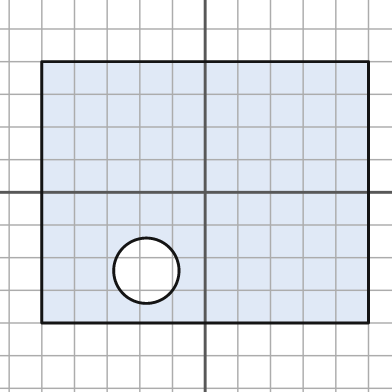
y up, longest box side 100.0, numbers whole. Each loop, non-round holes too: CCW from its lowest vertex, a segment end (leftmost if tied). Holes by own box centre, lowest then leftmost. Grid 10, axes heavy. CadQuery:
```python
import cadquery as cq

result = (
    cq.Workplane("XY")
    .moveTo(-50.0, -40.0)
    .lineTo(50.0, -40.0)
    .lineTo(50.0, 40.0)
    .lineTo(-50.0, 40.0)
    .close()
    .moveTo(-18.0, -24.0)
    .circle(10.0)
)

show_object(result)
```